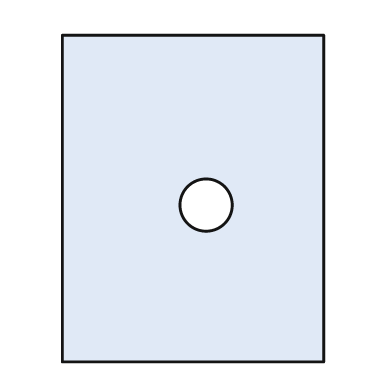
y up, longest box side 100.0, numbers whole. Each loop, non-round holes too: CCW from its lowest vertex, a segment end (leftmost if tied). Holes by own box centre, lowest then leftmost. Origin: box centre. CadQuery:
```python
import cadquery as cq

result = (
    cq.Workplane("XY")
    .moveTo(-40.0, -50.0)
    .lineTo(40.0, -50.0)
    .lineTo(40.0, 50.0)
    .lineTo(-40.0, 50.0)
    .close()
    .moveTo(4.0, -2.0)
    .circle(8.0)
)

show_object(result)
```